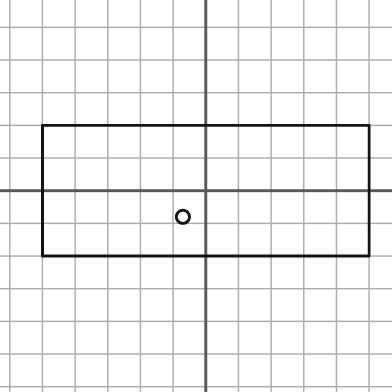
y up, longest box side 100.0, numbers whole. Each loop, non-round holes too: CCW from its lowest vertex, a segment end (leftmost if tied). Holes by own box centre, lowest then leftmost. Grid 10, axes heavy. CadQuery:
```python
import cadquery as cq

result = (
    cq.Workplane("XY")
    .moveTo(-50.0, -20.0)
    .lineTo(50.0, -20.0)
    .lineTo(50.0, 20.0)
    .lineTo(-50.0, 20.0)
    .close()
    .moveTo(-7.0, -8.0)
    .circle(2.0)
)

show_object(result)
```